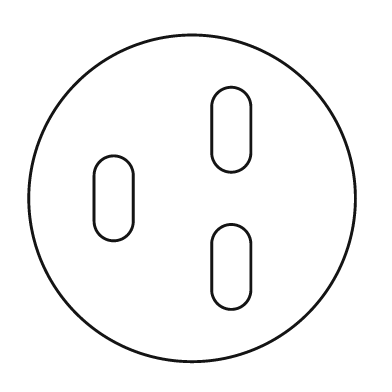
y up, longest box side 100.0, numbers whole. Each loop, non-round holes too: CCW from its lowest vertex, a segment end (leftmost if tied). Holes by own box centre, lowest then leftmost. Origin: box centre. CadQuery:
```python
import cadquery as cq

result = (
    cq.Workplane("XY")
    .moveTo(0.0, 0.0)
    .circle(50.0)
    .moveTo(6.0, -28.0)
    .threePointArc((12.0, -34.0), (18.0, -28.0))
    .lineTo(18.0, -14.0)
    .threePointArc((12.0, -8.0), (6.0, -14.0))
    .close()
    .moveTo(-30.0, -7.0)
    .threePointArc((-24.0, -13.0), (-18.0, -7.0))
    .lineTo(-18.0, 7.0)
    .threePointArc((-24.0, 13.0), (-30.0, 7.0))
    .close()
    .moveTo(6.0, 14.0)
    .threePointArc((12.0, 8.0), (18.0, 14.0))
    .lineTo(18.0, 28.0)
    .threePointArc((12.0, 34.0), (6.0, 28.0))
    .close()
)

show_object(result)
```